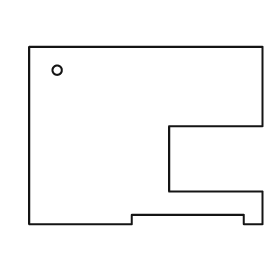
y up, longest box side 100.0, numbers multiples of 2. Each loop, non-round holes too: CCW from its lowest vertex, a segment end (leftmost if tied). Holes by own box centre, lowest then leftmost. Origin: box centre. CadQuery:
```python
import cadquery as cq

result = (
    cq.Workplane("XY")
    .moveTo(-50.0, -38.0)
    .lineTo(-6.0, -38.0)
    .lineTo(-6.0, -34.0)
    .lineTo(42.0, -34.0)
    .lineTo(42.0, -38.0)
    .lineTo(50.0, -38.0)
    .lineTo(50.0, -24.0)
    .lineTo(10.0, -24.0)
    .lineTo(10.0, 4.0)
    .lineTo(50.0, 4.0)
    .lineTo(50.0, 38.0)
    .lineTo(-50.0, 38.0)
    .close()
    .moveTo(-38.0, 28.0)
    .circle(2.0)
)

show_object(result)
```